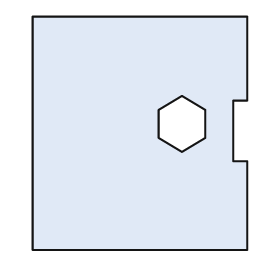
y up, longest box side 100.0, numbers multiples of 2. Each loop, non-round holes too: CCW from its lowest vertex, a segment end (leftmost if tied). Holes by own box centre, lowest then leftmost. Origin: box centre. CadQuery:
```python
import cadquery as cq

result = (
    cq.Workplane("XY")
    .moveTo(-46.0, -50.0)
    .lineTo(46.0, -50.0)
    .lineTo(46.0, -12.0)
    .lineTo(40.0, -12.0)
    .lineTo(40.0, 14.0)
    .lineTo(46.0, 14.0)
    .lineTo(46.0, 50.0)
    .lineTo(-46.0, 50.0)
    .close()
    .moveTo(18.0, -8.0)
    .lineTo(28.0, -2.0)
    .lineTo(28.0, 10.0)
    .lineTo(18.0, 16.0)
    .lineTo(8.0, 10.0)
    .lineTo(8.0, -2.0)
    .close()
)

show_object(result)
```